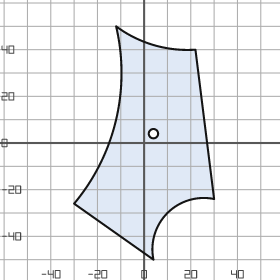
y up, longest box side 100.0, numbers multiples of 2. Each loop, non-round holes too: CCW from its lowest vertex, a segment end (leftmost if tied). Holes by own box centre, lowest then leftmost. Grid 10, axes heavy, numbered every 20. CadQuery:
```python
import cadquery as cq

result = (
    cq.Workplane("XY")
    .moveTo(4.0, -50.0)
    .threePointArc((10.0, -30.0), (30.0, -24.0))
    .lineTo(22.0, 40.0)
    .threePointArc((4.0, 42.0), (-12.0, 50.0))
    .threePointArc((-12.0, 10.0), (-30.0, -26.0))
    .close()
    .moveTo(4.0, 4.0)
    .circle(2.0)
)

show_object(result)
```